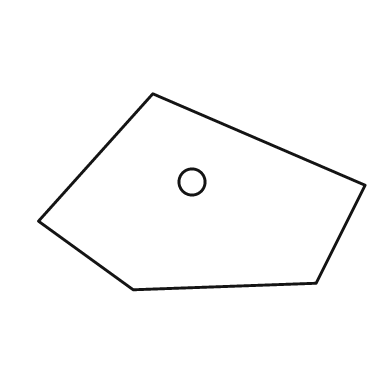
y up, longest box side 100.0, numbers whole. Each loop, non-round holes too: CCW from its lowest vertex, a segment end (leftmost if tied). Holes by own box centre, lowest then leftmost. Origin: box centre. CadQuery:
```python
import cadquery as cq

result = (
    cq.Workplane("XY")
    .moveTo(-21.0, -30.0)
    .lineTo(35.0, -28.0)
    .lineTo(50.0, 2.0)
    .lineTo(-15.0, 30.0)
    .lineTo(-50.0, -9.0)
    .close()
    .moveTo(-3.0, 3.0)
    .circle(4.0)
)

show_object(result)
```